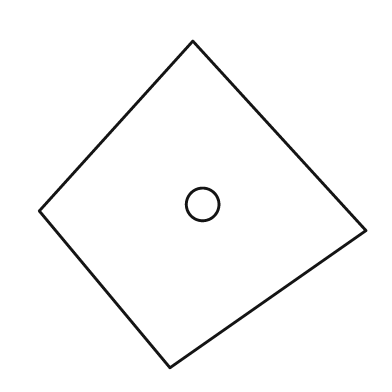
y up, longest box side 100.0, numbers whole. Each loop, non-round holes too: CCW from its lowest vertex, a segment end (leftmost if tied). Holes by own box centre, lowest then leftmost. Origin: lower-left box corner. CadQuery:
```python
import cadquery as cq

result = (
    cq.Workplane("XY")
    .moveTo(40.0, 0.0)
    .lineTo(100.0, 42.0)
    .lineTo(47.0, 100.0)
    .lineTo(0.0, 48.0)
    .close()
    .moveTo(50.0, 50.0)
    .circle(5.0)
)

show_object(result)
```